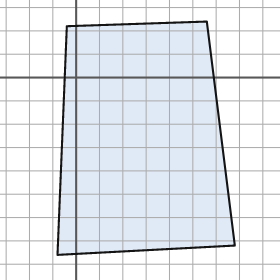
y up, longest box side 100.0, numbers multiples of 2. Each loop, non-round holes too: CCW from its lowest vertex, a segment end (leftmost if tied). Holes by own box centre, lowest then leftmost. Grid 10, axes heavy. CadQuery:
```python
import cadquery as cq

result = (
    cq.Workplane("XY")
    .moveTo(-8.0, -76.0)
    .lineTo(68.0, -72.0)
    .lineTo(56.0, 24.0)
    .lineTo(-4.0, 22.0)
    .close()
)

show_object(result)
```